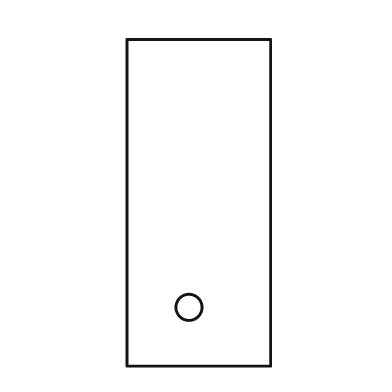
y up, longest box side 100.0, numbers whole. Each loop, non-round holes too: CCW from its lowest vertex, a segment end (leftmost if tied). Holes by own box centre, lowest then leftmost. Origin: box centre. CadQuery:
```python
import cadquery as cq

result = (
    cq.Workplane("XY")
    .moveTo(-22.0, -50.0)
    .lineTo(22.0, -50.0)
    .lineTo(22.0, 50.0)
    .lineTo(-22.0, 50.0)
    .close()
    .moveTo(-3.0, -32.0)
    .circle(4.0)
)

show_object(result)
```